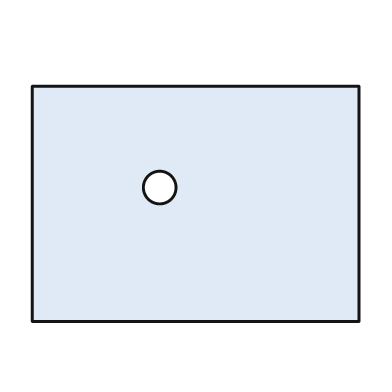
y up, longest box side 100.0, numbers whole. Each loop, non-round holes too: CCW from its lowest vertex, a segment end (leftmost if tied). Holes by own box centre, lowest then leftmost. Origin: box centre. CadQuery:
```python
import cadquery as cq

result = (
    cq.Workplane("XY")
    .moveTo(-50.0, -36.0)
    .lineTo(50.0, -36.0)
    .lineTo(50.0, 36.0)
    .lineTo(-50.0, 36.0)
    .close()
    .moveTo(-11.0, 5.0)
    .circle(5.0)
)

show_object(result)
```